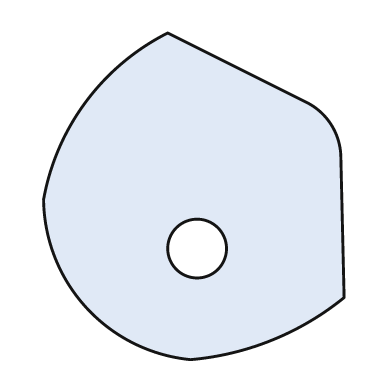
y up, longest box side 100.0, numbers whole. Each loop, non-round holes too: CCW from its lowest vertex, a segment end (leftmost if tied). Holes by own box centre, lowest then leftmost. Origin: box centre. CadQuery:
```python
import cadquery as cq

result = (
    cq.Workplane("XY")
    .moveTo(-1.0, -50.0)
    .threePointArc((24.0, -44.0), (46.0, -31.0))
    .lineTo(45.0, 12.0)
    .threePointArc((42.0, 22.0), (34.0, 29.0))
    .lineTo(-8.0, 50.0)
    .threePointArc((-33.0, 29.0), (-46.0, -1.0))
    .threePointArc((-33.0, -34.0), (-1.0, -50.0))
    .close()
    .moveTo(1.0, -16.0)
    .circle(9.0)
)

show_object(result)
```